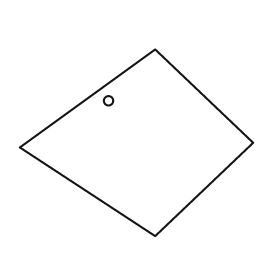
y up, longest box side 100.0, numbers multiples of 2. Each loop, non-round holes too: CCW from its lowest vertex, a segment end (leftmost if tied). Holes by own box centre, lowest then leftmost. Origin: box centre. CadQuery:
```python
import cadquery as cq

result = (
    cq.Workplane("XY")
    .moveTo(8.0, -40.0)
    .lineTo(50.0, 0.0)
    .lineTo(8.0, 40.0)
    .lineTo(-50.0, -2.0)
    .close()
    .moveTo(-12.0, 18.0)
    .circle(2.0)
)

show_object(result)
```